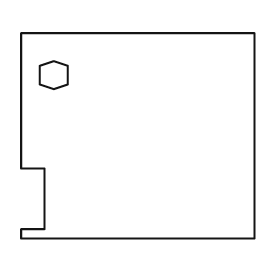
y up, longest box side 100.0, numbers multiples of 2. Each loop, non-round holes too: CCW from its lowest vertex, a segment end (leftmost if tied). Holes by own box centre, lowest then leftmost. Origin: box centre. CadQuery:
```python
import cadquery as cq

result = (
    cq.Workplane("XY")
    .moveTo(-50.0, -44.0)
    .lineTo(50.0, -44.0)
    .lineTo(50.0, 44.0)
    .lineTo(-50.0, 44.0)
    .lineTo(-50.0, -14.0)
    .lineTo(-40.0, -14.0)
    .lineTo(-40.0, -40.0)
    .lineTo(-50.0, -40.0)
    .close()
    .moveTo(-36.0, 20.0)
    .lineTo(-30.0, 22.0)
    .lineTo(-30.0, 30.0)
    .lineTo(-36.0, 32.0)
    .lineTo(-42.0, 30.0)
    .lineTo(-42.0, 22.0)
    .close()
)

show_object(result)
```